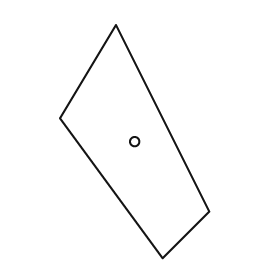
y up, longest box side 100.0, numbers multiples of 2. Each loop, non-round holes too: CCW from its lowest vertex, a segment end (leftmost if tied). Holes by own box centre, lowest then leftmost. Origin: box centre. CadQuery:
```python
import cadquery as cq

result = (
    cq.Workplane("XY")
    .moveTo(12.0, -50.0)
    .lineTo(32.0, -30.0)
    .lineTo(-8.0, 50.0)
    .lineTo(-32.0, 10.0)
    .close()
    .moveTo(0.0, 0.0)
    .circle(2.0)
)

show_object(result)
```